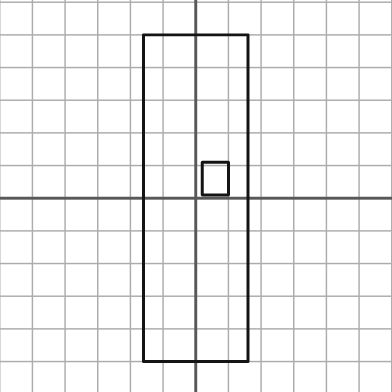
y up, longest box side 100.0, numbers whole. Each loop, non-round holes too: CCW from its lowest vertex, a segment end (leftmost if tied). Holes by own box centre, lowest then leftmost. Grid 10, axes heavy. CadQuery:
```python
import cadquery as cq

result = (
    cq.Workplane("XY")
    .moveTo(-16.0, -50.0)
    .lineTo(16.0, -50.0)
    .lineTo(16.0, 50.0)
    .lineTo(-16.0, 50.0)
    .close()
    .moveTo(2.0, 1.0)
    .lineTo(10.0, 1.0)
    .lineTo(10.0, 11.0)
    .lineTo(2.0, 11.0)
    .close()
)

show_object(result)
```